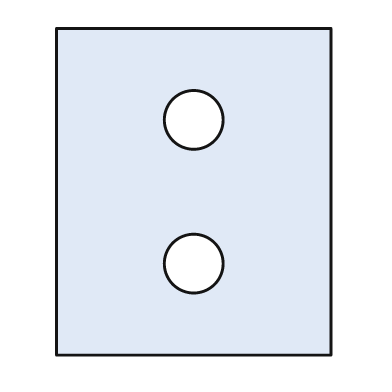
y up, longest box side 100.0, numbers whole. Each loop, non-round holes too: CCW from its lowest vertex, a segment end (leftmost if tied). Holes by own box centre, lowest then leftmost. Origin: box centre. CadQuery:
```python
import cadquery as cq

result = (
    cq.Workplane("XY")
    .moveTo(-42.0, -50.0)
    .lineTo(42.0, -50.0)
    .lineTo(42.0, 50.0)
    .lineTo(-42.0, 50.0)
    .close()
    .moveTo(0.0, -22.0)
    .circle(9.0)
    .moveTo(0.0, 22.0)
    .circle(9.0)
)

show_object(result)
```